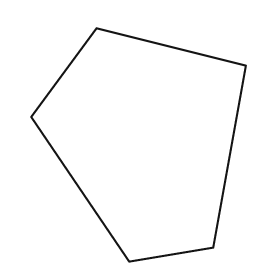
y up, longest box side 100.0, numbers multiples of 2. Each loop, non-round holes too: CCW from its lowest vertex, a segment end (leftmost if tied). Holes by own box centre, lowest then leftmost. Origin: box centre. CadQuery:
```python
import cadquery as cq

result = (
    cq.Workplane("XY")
    .moveTo(-4.0, -50.0)
    .lineTo(32.0, -44.0)
    .lineTo(46.0, 34.0)
    .lineTo(-18.0, 50.0)
    .lineTo(-46.0, 12.0)
    .close()
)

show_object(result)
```